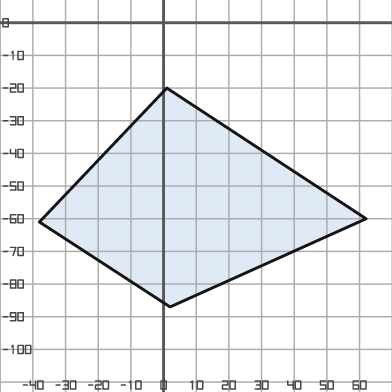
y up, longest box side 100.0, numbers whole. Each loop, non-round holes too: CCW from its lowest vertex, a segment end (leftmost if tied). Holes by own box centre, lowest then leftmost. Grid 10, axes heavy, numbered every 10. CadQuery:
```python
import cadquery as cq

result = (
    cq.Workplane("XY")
    .moveTo(2.0, -87.0)
    .lineTo(62.0, -60.0)
    .lineTo(1.0, -20.0)
    .lineTo(-38.0, -61.0)
    .close()
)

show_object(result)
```